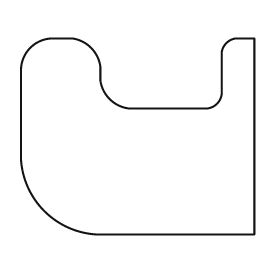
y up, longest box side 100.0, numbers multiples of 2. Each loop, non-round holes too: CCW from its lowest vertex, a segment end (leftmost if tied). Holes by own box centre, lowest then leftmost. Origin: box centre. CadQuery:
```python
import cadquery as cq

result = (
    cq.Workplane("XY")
    .moveTo(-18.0, -42.0)
    .lineTo(50.0, -42.0)
    .lineTo(50.0, 42.0)
    .lineTo(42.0, 42.0)
    .threePointArc((38.0, 40.0), (36.0, 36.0))
    .lineTo(36.0, 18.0)
    .threePointArc((34.0, 14.0), (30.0, 12.0))
    .lineTo(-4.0, 12.0)
    .threePointArc((-12.0, 16.0), (-16.0, 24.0))
    .lineTo(-16.0, 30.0)
    .threePointArc((-20.0, 38.0), (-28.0, 42.0))
    .lineTo(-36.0, 42.0)
    .threePointArc((-46.0, 38.0), (-50.0, 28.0))
    .lineTo(-50.0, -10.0)
    .threePointArc((-40.0, -32.0), (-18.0, -42.0))
    .close()
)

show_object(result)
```